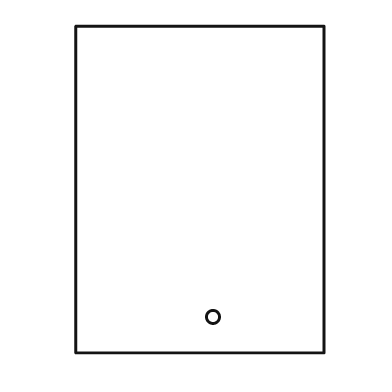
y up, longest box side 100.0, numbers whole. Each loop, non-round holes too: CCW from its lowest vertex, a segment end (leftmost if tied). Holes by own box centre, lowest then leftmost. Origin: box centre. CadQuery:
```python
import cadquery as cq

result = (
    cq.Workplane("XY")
    .moveTo(-38.0, -50.0)
    .lineTo(38.0, -50.0)
    .lineTo(38.0, 50.0)
    .lineTo(-38.0, 50.0)
    .close()
    .moveTo(4.0, -39.0)
    .circle(2.0)
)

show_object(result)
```